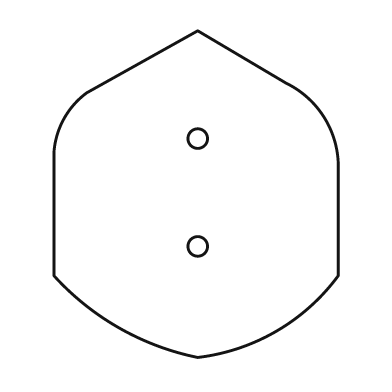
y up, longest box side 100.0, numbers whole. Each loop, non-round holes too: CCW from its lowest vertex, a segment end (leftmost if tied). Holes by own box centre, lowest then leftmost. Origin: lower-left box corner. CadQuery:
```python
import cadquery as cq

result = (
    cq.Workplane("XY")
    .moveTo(44.0, 0.0)
    .threePointArc((68.0, 8.0), (87.0, 25.0))
    .lineTo(87.0, 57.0)
    .threePointArc((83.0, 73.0), (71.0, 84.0))
    .lineTo(44.0, 100.0)
    .lineTo(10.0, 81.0)
    .threePointArc((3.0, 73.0), (0.0, 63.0))
    .lineTo(0.0, 25.0)
    .threePointArc((20.0, 9.0), (44.0, 0.0))
    .close()
    .moveTo(44.0, 34.0)
    .circle(3.0)
    .moveTo(44.0, 67.0)
    .circle(3.0)
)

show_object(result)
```